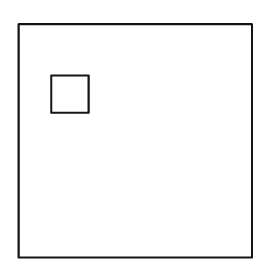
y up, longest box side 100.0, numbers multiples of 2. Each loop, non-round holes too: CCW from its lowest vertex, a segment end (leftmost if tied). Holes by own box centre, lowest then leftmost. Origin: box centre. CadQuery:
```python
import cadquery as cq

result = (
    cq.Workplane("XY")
    .moveTo(-50.0, -50.0)
    .lineTo(50.0, -50.0)
    .lineTo(50.0, 50.0)
    .lineTo(-50.0, 50.0)
    .close()
    .moveTo(-36.0, 12.0)
    .lineTo(-20.0, 12.0)
    .lineTo(-20.0, 28.0)
    .lineTo(-36.0, 28.0)
    .close()
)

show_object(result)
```